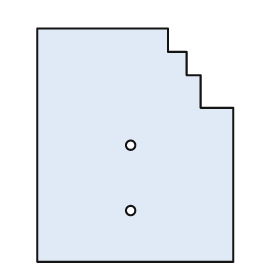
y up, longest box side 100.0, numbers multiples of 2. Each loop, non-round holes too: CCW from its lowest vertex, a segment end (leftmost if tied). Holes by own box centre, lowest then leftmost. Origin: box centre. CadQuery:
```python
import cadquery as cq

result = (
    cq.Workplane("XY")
    .moveTo(-42.0, -50.0)
    .lineTo(42.0, -50.0)
    .lineTo(42.0, 16.0)
    .lineTo(28.0, 16.0)
    .lineTo(28.0, 30.0)
    .lineTo(22.0, 30.0)
    .lineTo(22.0, 40.0)
    .lineTo(14.0, 40.0)
    .lineTo(14.0, 50.0)
    .lineTo(-42.0, 50.0)
    .close()
    .moveTo(-2.0, -28.0)
    .circle(2.0)
    .moveTo(-2.0, 0.0)
    .circle(2.0)
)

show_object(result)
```